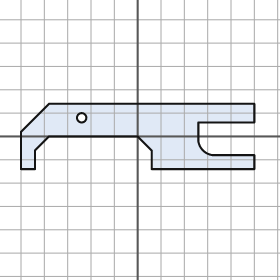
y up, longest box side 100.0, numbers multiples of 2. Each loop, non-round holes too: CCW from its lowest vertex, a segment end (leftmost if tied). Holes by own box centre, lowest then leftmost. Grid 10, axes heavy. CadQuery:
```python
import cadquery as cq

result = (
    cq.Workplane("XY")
    .moveTo(-50.0, -14.0)
    .lineTo(-44.0, -14.0)
    .lineTo(-44.0, -6.0)
    .lineTo(-38.0, 0.0)
    .lineTo(0.0, 0.0)
    .lineTo(6.0, -6.0)
    .lineTo(6.0, -14.0)
    .lineTo(50.0, -14.0)
    .lineTo(50.0, -8.0)
    .lineTo(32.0, -8.0)
    .threePointArc((28.0, -6.0), (26.0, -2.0))
    .lineTo(26.0, 6.0)
    .lineTo(50.0, 6.0)
    .lineTo(50.0, 14.0)
    .lineTo(-38.0, 14.0)
    .lineTo(-50.0, 2.0)
    .close()
    .moveTo(-24.0, 8.0)
    .circle(2.0)
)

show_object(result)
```